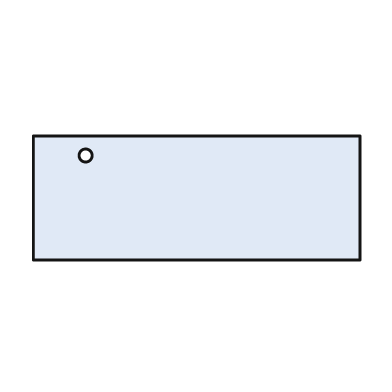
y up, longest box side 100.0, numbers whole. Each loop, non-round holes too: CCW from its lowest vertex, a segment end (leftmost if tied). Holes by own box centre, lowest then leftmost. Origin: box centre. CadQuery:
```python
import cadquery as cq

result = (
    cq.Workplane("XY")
    .moveTo(-50.0, -19.0)
    .lineTo(50.0, -19.0)
    .lineTo(50.0, 19.0)
    .lineTo(-50.0, 19.0)
    .close()
    .moveTo(-34.0, 13.0)
    .circle(2.0)
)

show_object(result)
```